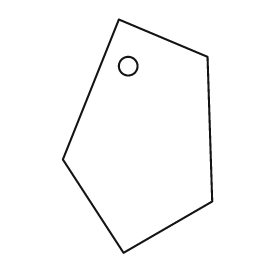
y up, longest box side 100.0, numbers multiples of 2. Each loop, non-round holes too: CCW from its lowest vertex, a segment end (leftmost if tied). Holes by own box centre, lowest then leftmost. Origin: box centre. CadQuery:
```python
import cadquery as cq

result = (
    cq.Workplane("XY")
    .moveTo(-6.0, -50.0)
    .lineTo(32.0, -28.0)
    .lineTo(30.0, 34.0)
    .lineTo(-8.0, 50.0)
    .lineTo(-32.0, -10.0)
    .close()
    .moveTo(-4.0, 30.0)
    .circle(4.0)
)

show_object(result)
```